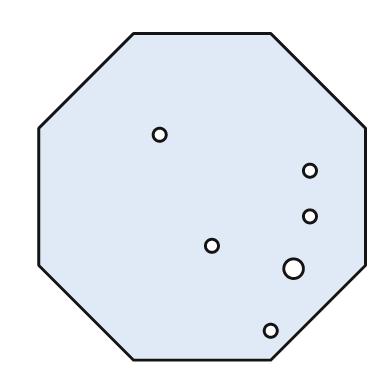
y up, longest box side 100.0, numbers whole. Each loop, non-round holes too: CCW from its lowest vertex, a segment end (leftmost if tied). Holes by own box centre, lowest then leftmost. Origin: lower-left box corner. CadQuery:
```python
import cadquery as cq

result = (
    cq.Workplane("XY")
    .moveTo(29.0, 0.0)
    .lineTo(71.0, 0.0)
    .lineTo(100.0, 29.0)
    .lineTo(100.0, 71.0)
    .lineTo(71.0, 100.0)
    .lineTo(29.0, 100.0)
    .lineTo(0.0, 71.0)
    .lineTo(0.0, 29.0)
    .close()
    .moveTo(71.0, 9.0)
    .circle(2.0)
    .moveTo(78.0, 28.0)
    .circle(3.0)
    .moveTo(53.0, 35.0)
    .circle(2.0)
    .moveTo(83.0, 44.0)
    .circle(2.0)
    .moveTo(83.0, 58.0)
    .circle(2.0)
    .moveTo(37.0, 69.0)
    .circle(2.0)
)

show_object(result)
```